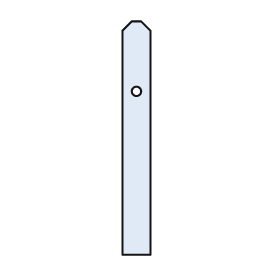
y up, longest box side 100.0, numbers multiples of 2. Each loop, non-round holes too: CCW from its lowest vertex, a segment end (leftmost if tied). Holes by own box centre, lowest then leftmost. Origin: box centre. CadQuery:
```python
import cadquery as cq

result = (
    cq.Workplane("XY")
    .moveTo(-6.0, -50.0)
    .lineTo(6.0, -50.0)
    .lineTo(6.0, 46.0)
    .lineTo(2.0, 50.0)
    .lineTo(-2.0, 50.0)
    .lineTo(-6.0, 46.0)
    .close()
    .moveTo(0.0, 20.0)
    .circle(2.0)
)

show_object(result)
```